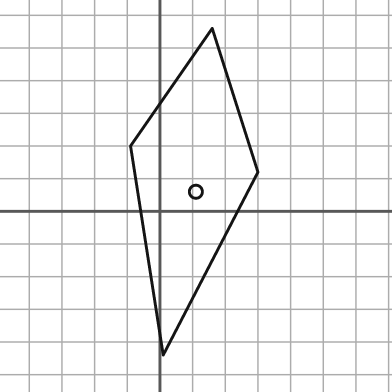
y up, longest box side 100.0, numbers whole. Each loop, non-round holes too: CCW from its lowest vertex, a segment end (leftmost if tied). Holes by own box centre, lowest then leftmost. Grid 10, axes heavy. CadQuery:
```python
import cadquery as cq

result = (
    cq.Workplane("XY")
    .moveTo(1.0, -44.0)
    .lineTo(30.0, 12.0)
    .lineTo(16.0, 56.0)
    .lineTo(-9.0, 20.0)
    .close()
    .moveTo(11.0, 6.0)
    .circle(2.0)
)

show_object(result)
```